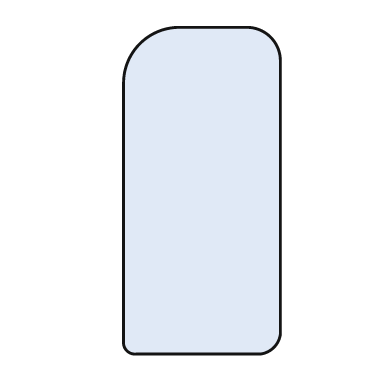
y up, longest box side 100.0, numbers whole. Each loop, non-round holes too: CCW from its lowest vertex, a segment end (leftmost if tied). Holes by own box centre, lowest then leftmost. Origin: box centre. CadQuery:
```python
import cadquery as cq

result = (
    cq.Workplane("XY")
    .moveTo(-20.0, -50.0)
    .lineTo(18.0, -50.0)
    .threePointArc((22.0, -48.0), (24.0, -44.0))
    .lineTo(24.0, 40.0)
    .threePointArc((21.0, 47.0), (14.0, 50.0))
    .lineTo(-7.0, 50.0)
    .threePointArc((-19.0, 45.0), (-24.0, 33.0))
    .lineTo(-24.0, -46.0)
    .threePointArc((-23.0, -49.0), (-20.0, -50.0))
    .close()
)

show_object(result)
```